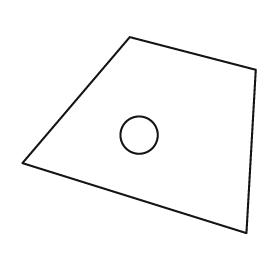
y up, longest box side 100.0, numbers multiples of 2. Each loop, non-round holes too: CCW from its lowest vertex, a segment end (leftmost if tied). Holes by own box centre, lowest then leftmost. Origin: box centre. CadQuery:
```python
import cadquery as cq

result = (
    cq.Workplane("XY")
    .moveTo(46.0, -42.0)
    .lineTo(50.0, 28.0)
    .lineTo(-4.0, 42.0)
    .lineTo(-50.0, -12.0)
    .close()
    .moveTo(0.0, 0.0)
    .circle(8.0)
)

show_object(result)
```